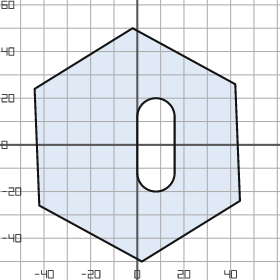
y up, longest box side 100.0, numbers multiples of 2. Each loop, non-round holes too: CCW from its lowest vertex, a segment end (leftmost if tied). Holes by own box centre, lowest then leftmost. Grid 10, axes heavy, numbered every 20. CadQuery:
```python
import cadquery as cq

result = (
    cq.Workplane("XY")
    .moveTo(2.0, -50.0)
    .lineTo(44.0, -24.0)
    .lineTo(42.0, 26.0)
    .lineTo(-2.0, 50.0)
    .lineTo(-44.0, 24.0)
    .lineTo(-42.0, -26.0)
    .close()
    .moveTo(0.0, -12.0)
    .threePointArc((8.0, -20.0), (16.0, -12.0))
    .lineTo(16.0, 12.0)
    .threePointArc((8.0, 20.0), (0.0, 12.0))
    .close()
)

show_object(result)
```